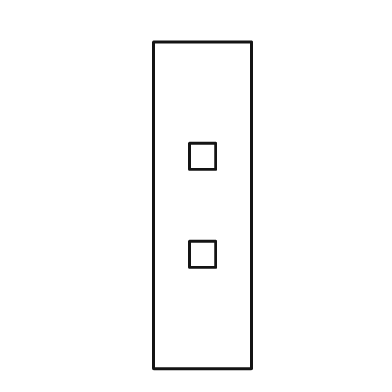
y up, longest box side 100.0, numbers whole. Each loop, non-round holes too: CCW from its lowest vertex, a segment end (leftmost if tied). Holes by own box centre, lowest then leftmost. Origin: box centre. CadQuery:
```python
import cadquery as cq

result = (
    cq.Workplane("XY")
    .moveTo(-15.0, -50.0)
    .lineTo(15.0, -50.0)
    .lineTo(15.0, 50.0)
    .lineTo(-15.0, 50.0)
    .close()
    .moveTo(-4.0, -19.0)
    .lineTo(4.0, -19.0)
    .lineTo(4.0, -11.0)
    .lineTo(-4.0, -11.0)
    .close()
    .moveTo(-4.0, 11.0)
    .lineTo(4.0, 11.0)
    .lineTo(4.0, 19.0)
    .lineTo(-4.0, 19.0)
    .close()
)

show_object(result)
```